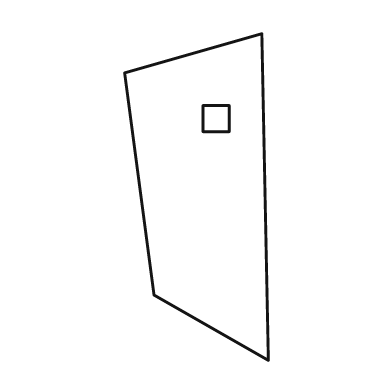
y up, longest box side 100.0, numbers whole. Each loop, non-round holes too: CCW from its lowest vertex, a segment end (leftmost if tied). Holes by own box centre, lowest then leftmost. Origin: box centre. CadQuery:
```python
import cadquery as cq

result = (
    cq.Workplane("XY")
    .moveTo(22.0, -50.0)
    .lineTo(20.0, 50.0)
    .lineTo(-22.0, 38.0)
    .lineTo(-13.0, -30.0)
    .close()
    .moveTo(2.0, 20.0)
    .lineTo(10.0, 20.0)
    .lineTo(10.0, 28.0)
    .lineTo(2.0, 28.0)
    .close()
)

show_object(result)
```